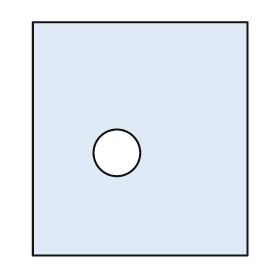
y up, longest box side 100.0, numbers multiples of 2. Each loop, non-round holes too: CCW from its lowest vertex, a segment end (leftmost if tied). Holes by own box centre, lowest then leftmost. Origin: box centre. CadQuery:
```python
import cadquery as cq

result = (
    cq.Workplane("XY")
    .moveTo(-46.0, -50.0)
    .lineTo(46.0, -50.0)
    .lineTo(46.0, 50.0)
    .lineTo(-46.0, 50.0)
    .close()
    .moveTo(-10.0, -6.0)
    .circle(10.0)
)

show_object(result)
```